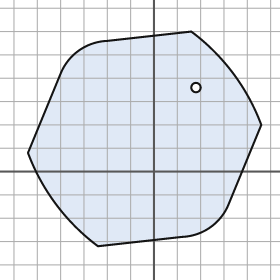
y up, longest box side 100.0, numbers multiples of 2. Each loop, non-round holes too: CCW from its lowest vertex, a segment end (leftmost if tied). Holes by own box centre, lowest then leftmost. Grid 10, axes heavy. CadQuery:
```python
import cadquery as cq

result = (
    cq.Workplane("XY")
    .moveTo(-24.0, -32.0)
    .lineTo(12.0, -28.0)
    .threePointArc((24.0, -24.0), (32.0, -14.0))
    .lineTo(46.0, 20.0)
    .threePointArc((34.0, 42.0), (16.0, 60.0))
    .lineTo(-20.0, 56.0)
    .threePointArc((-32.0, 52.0), (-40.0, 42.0))
    .lineTo(-54.0, 8.0)
    .threePointArc((-42.0, -14.0), (-24.0, -32.0))
    .close()
    .moveTo(18.0, 36.0)
    .circle(2.0)
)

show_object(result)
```